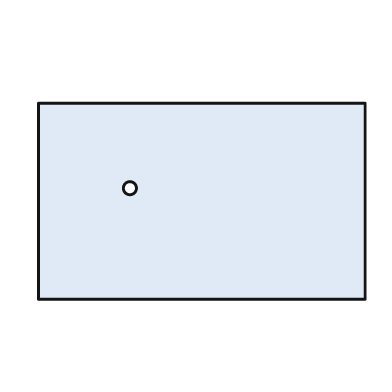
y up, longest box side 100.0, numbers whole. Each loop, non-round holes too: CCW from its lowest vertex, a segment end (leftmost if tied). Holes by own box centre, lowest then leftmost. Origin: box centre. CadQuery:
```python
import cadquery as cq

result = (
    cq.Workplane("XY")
    .moveTo(-50.0, -30.0)
    .lineTo(50.0, -30.0)
    .lineTo(50.0, 30.0)
    .lineTo(-50.0, 30.0)
    .close()
    .moveTo(-22.0, 4.0)
    .circle(2.0)
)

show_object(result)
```